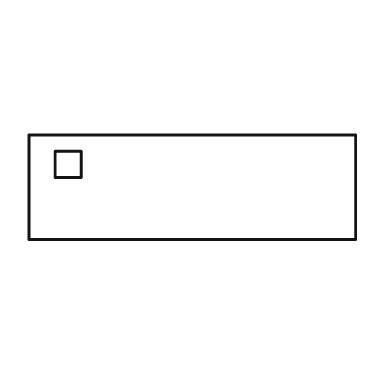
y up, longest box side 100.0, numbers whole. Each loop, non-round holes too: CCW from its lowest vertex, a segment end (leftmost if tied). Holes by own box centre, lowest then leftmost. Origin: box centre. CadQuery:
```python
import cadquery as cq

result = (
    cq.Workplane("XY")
    .moveTo(-50.0, -16.0)
    .lineTo(50.0, -16.0)
    .lineTo(50.0, 16.0)
    .lineTo(-50.0, 16.0)
    .close()
    .moveTo(-42.0, 3.0)
    .lineTo(-34.0, 3.0)
    .lineTo(-34.0, 11.0)
    .lineTo(-42.0, 11.0)
    .close()
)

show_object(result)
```